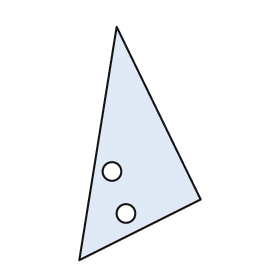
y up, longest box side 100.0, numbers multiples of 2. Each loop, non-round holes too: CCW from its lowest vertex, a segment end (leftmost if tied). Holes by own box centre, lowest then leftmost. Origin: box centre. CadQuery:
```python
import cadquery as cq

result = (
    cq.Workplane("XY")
    .moveTo(-26.0, -50.0)
    .lineTo(26.0, -24.0)
    .lineTo(-10.0, 50.0)
    .close()
    .moveTo(-6.0, -30.0)
    .circle(4.0)
    .moveTo(-12.0, -12.0)
    .circle(4.0)
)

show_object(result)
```